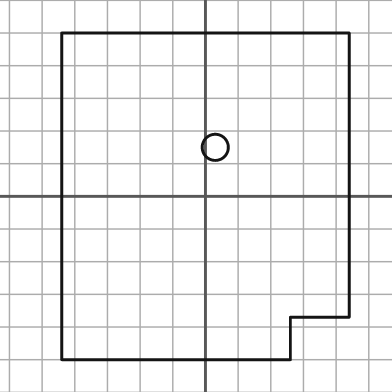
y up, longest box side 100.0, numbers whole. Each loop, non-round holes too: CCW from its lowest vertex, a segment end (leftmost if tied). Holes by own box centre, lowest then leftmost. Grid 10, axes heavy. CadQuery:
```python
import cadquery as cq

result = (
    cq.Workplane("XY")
    .moveTo(-44.0, -50.0)
    .lineTo(26.0, -50.0)
    .lineTo(26.0, -37.0)
    .lineTo(44.0, -37.0)
    .lineTo(44.0, 50.0)
    .lineTo(-44.0, 50.0)
    .close()
    .moveTo(3.0, 15.0)
    .circle(4.0)
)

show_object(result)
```